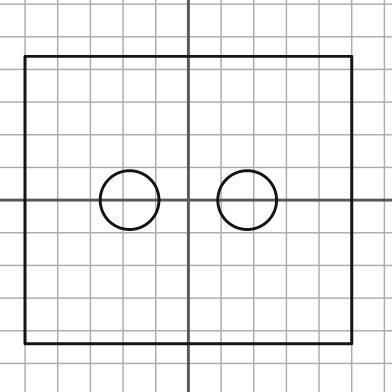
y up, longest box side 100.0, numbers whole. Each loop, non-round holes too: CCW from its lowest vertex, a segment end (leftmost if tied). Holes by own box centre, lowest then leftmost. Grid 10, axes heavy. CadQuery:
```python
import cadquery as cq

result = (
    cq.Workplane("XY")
    .moveTo(-50.0, -44.0)
    .lineTo(50.0, -44.0)
    .lineTo(50.0, 44.0)
    .lineTo(-50.0, 44.0)
    .close()
    .moveTo(-18.0, 0.0)
    .circle(9.0)
    .moveTo(18.0, 0.0)
    .circle(9.0)
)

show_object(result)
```